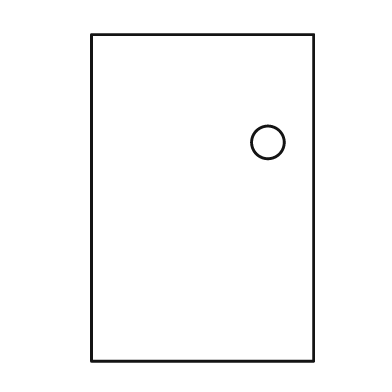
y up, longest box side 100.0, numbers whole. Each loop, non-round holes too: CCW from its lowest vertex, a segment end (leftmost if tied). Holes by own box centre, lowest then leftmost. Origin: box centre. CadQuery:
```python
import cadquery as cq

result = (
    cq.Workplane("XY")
    .moveTo(-34.0, -50.0)
    .lineTo(34.0, -50.0)
    .lineTo(34.0, 50.0)
    .lineTo(-34.0, 50.0)
    .close()
    .moveTo(20.0, 17.0)
    .circle(5.0)
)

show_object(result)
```